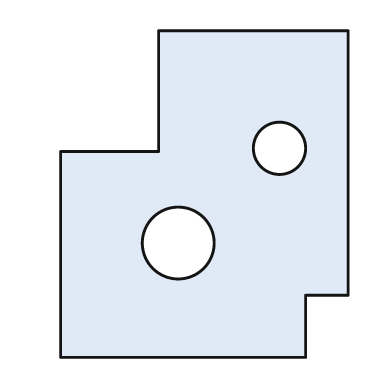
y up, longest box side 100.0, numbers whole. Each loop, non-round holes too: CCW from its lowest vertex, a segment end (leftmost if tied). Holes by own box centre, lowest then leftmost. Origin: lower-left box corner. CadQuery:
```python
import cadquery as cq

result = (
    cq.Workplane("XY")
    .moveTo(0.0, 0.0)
    .lineTo(75.0, 0.0)
    .lineTo(75.0, 19.0)
    .lineTo(88.0, 19.0)
    .lineTo(88.0, 100.0)
    .lineTo(30.0, 100.0)
    .lineTo(30.0, 63.0)
    .lineTo(0.0, 63.0)
    .close()
    .moveTo(36.0, 35.0)
    .circle(11.0)
    .moveTo(67.0, 64.0)
    .circle(8.0)
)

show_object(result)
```